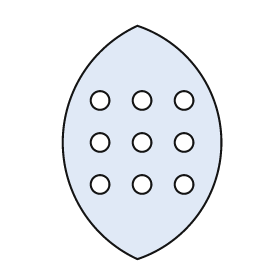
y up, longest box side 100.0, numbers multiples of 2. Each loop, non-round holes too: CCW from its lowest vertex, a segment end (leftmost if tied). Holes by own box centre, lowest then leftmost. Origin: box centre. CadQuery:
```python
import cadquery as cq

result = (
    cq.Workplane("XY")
    .moveTo(-2.0, -50.0)
    .threePointArc((34.0, 0.0), (-2.0, 50.0))
    .threePointArc((-34.0, 0.0), (-2.0, -50.0))
    .close()
    .moveTo(-18.0, -18.0)
    .circle(4.0)
    .moveTo(0.0, -18.0)
    .circle(4.0)
    .moveTo(18.0, -18.0)
    .circle(4.0)
    .moveTo(-18.0, 0.0)
    .circle(4.0)
    .moveTo(0.0, 0.0)
    .circle(4.0)
    .moveTo(18.0, 0.0)
    .circle(4.0)
    .moveTo(-18.0, 18.0)
    .circle(4.0)
    .moveTo(0.0, 18.0)
    .circle(4.0)
    .moveTo(18.0, 18.0)
    .circle(4.0)
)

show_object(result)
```